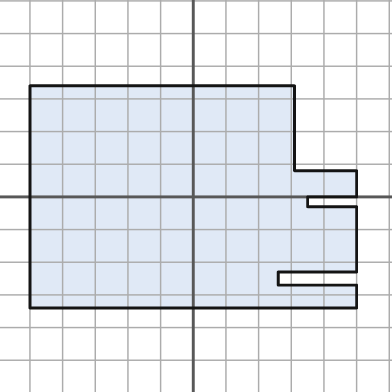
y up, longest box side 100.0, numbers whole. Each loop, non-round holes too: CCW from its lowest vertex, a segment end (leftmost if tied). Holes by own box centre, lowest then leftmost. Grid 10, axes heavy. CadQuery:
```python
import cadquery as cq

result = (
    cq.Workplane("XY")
    .moveTo(-50.0, -34.0)
    .lineTo(50.0, -34.0)
    .lineTo(50.0, -27.0)
    .lineTo(26.0, -27.0)
    .lineTo(26.0, -23.0)
    .lineTo(50.0, -23.0)
    .lineTo(50.0, -3.0)
    .lineTo(35.0, -3.0)
    .lineTo(35.0, 0.0)
    .lineTo(50.0, 0.0)
    .lineTo(50.0, 8.0)
    .lineTo(31.0, 8.0)
    .lineTo(31.0, 34.0)
    .lineTo(-50.0, 34.0)
    .close()
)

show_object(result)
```